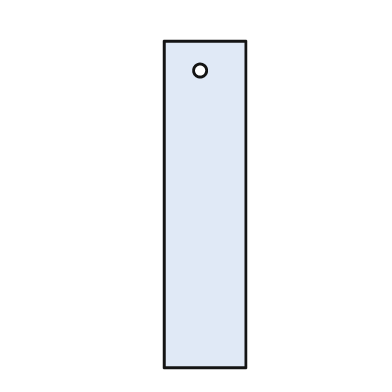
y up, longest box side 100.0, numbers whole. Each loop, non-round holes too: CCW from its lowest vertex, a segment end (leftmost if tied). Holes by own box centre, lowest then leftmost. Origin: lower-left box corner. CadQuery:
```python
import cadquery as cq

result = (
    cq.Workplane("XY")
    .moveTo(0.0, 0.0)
    .lineTo(25.0, 0.0)
    .lineTo(25.0, 100.0)
    .lineTo(0.0, 100.0)
    .close()
    .moveTo(11.0, 91.0)
    .circle(2.0)
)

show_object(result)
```